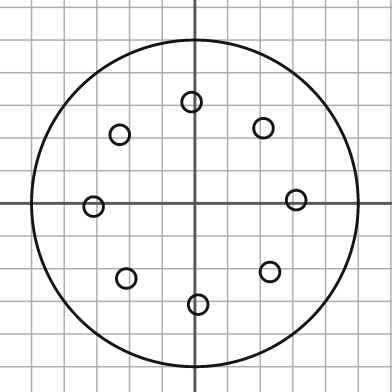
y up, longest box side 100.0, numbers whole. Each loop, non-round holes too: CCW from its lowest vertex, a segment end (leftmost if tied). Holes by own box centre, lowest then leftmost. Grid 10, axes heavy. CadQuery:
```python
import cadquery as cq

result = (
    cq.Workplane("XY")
    .moveTo(0.0, 0.0)
    .circle(50.0)
    .moveTo(1.0, -31.0)
    .circle(3.0)
    .moveTo(-21.0, -23.0)
    .circle(3.0)
    .moveTo(23.0, -21.0)
    .circle(3.0)
    .moveTo(-31.0, -1.0)
    .circle(3.0)
    .moveTo(31.0, 1.0)
    .circle(3.0)
    .moveTo(-23.0, 21.0)
    .circle(3.0)
    .moveTo(21.0, 23.0)
    .circle(3.0)
    .moveTo(-1.0, 31.0)
    .circle(3.0)
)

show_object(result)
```